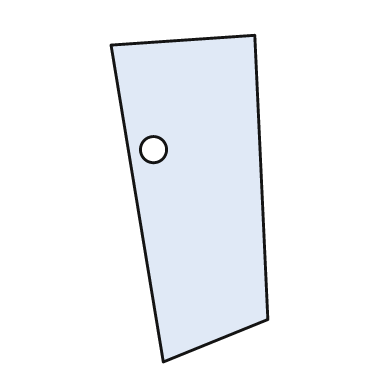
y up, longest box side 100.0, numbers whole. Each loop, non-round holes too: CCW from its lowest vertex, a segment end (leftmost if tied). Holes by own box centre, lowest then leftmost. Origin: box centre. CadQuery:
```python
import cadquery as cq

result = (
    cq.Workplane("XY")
    .moveTo(-8.0, -50.0)
    .lineTo(24.0, -37.0)
    .lineTo(20.0, 50.0)
    .lineTo(-24.0, 47.0)
    .close()
    .moveTo(-11.0, 15.0)
    .circle(4.0)
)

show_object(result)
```